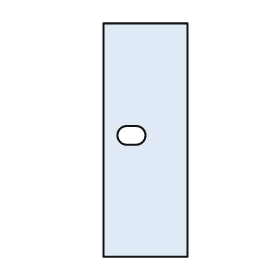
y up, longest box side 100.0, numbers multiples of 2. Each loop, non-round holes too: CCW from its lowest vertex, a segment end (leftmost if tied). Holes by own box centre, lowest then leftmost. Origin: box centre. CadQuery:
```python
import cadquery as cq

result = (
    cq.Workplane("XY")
    .moveTo(-18.0, -50.0)
    .lineTo(18.0, -50.0)
    .lineTo(18.0, 50.0)
    .lineTo(-18.0, 50.0)
    .close()
    .moveTo(-8.0, -2.0)
    .lineTo(-4.0, -2.0)
    .threePointArc((0.0, 2.0), (-4.0, 6.0))
    .lineTo(-8.0, 6.0)
    .threePointArc((-12.0, 2.0), (-8.0, -2.0))
    .close()
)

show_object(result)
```